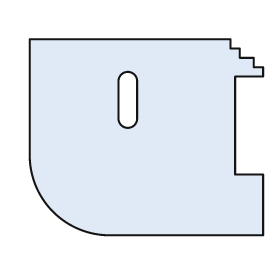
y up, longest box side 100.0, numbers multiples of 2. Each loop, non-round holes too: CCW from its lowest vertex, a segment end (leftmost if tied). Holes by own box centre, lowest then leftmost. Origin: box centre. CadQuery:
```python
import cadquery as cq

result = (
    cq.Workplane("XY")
    .moveTo(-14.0, -42.0)
    .lineTo(50.0, -42.0)
    .lineTo(50.0, -16.0)
    .lineTo(38.0, -16.0)
    .lineTo(38.0, 26.0)
    .lineTo(50.0, 26.0)
    .lineTo(50.0, 30.0)
    .lineTo(46.0, 30.0)
    .lineTo(46.0, 34.0)
    .lineTo(40.0, 34.0)
    .lineTo(40.0, 38.0)
    .lineTo(36.0, 38.0)
    .lineTo(36.0, 42.0)
    .lineTo(-50.0, 42.0)
    .lineTo(-50.0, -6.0)
    .threePointArc((-40.0, -32.0), (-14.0, -42.0))
    .close()
    .moveTo(-12.0, 8.0)
    .threePointArc((-8.0, 4.0), (-4.0, 8.0))
    .lineTo(-4.0, 24.0)
    .threePointArc((-8.0, 28.0), (-12.0, 24.0))
    .close()
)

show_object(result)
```